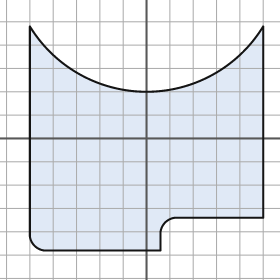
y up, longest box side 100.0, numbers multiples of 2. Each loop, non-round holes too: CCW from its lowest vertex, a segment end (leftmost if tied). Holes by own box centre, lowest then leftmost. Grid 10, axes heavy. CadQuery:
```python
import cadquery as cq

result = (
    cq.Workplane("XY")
    .moveTo(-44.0, -48.0)
    .lineTo(6.0, -48.0)
    .lineTo(6.0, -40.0)
    .threePointArc((8.0, -36.0), (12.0, -34.0))
    .lineTo(50.0, -34.0)
    .lineTo(50.0, 48.0)
    .threePointArc((0.0, 20.0), (-50.0, 48.0))
    .lineTo(-50.0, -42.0)
    .threePointArc((-48.0, -46.0), (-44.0, -48.0))
    .close()
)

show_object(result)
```